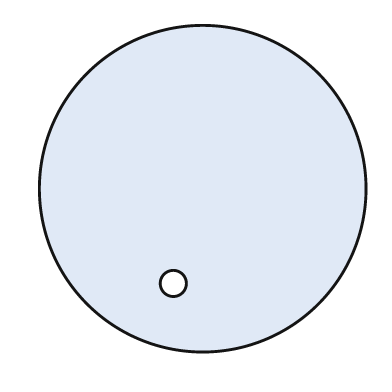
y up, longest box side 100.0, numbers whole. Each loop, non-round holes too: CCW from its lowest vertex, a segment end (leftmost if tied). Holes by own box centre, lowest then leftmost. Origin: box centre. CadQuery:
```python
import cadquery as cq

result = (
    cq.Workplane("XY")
    .moveTo(0.0, 0.0)
    .circle(50.0)
    .moveTo(-9.0, -29.0)
    .circle(4.0)
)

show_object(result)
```